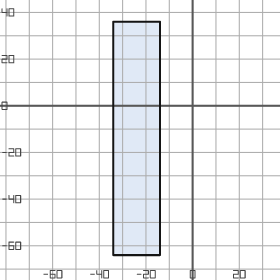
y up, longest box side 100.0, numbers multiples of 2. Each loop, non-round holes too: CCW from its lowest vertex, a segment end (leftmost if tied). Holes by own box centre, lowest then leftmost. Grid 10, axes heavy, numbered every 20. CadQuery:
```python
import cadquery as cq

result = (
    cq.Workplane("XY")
    .moveTo(-34.0, -64.0)
    .lineTo(-14.0, -64.0)
    .lineTo(-14.0, 36.0)
    .lineTo(-34.0, 36.0)
    .close()
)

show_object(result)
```